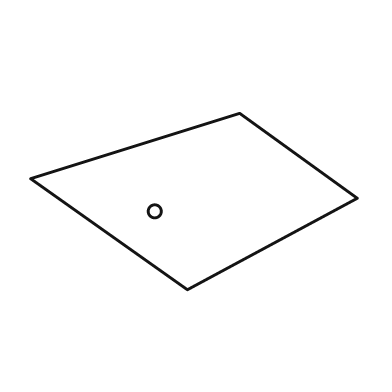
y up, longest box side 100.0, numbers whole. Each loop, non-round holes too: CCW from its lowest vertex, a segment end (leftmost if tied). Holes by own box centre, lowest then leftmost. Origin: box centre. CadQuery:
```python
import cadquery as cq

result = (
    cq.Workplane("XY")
    .moveTo(-2.0, -27.0)
    .lineTo(50.0, 1.0)
    .lineTo(14.0, 27.0)
    .lineTo(-50.0, 7.0)
    .close()
    .moveTo(-12.0, -3.0)
    .circle(2.0)
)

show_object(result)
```